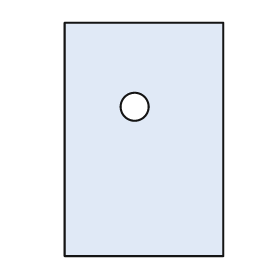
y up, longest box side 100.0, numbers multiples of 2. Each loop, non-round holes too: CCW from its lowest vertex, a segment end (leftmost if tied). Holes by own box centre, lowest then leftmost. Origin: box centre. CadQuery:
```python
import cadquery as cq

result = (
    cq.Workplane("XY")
    .moveTo(-34.0, -50.0)
    .lineTo(34.0, -50.0)
    .lineTo(34.0, 50.0)
    .lineTo(-34.0, 50.0)
    .close()
    .moveTo(-4.0, 14.0)
    .circle(6.0)
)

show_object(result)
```